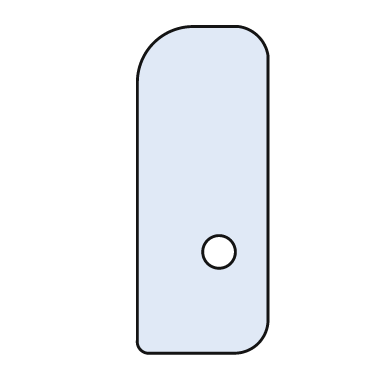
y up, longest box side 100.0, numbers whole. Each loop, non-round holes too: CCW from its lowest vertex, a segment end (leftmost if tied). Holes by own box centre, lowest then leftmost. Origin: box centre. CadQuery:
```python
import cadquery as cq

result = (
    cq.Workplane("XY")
    .moveTo(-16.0, -50.0)
    .lineTo(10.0, -50.0)
    .threePointArc((17.0, -47.0), (20.0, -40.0))
    .lineTo(20.0, 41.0)
    .threePointArc((17.0, 47.0), (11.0, 50.0))
    .lineTo(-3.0, 50.0)
    .threePointArc((-15.0, 45.0), (-20.0, 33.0))
    .lineTo(-20.0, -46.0)
    .threePointArc((-19.0, -49.0), (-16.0, -50.0))
    .close()
    .moveTo(5.0, -19.0)
    .circle(5.0)
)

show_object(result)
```